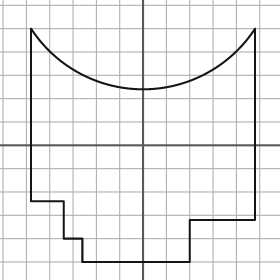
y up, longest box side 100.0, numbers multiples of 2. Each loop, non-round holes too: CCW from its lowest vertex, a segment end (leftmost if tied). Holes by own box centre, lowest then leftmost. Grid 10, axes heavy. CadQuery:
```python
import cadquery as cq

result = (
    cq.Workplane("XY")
    .moveTo(-26.0, -50.0)
    .lineTo(20.0, -50.0)
    .lineTo(20.0, -32.0)
    .lineTo(48.0, -32.0)
    .lineTo(48.0, 50.0)
    .threePointArc((0.0, 24.0), (-48.0, 50.0))
    .lineTo(-48.0, -24.0)
    .lineTo(-34.0, -24.0)
    .lineTo(-34.0, -40.0)
    .lineTo(-26.0, -40.0)
    .close()
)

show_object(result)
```